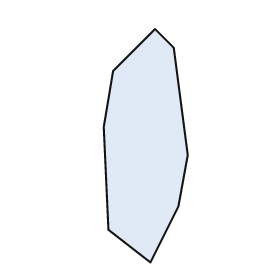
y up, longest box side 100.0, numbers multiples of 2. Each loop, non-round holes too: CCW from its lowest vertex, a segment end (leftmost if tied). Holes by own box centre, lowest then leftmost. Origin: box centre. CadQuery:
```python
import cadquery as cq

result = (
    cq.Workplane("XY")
    .moveTo(2.0, -50.0)
    .lineTo(14.0, -26.0)
    .lineTo(18.0, -4.0)
    .lineTo(12.0, 42.0)
    .lineTo(4.0, 50.0)
    .lineTo(-14.0, 32.0)
    .lineTo(-18.0, 8.0)
    .lineTo(-16.0, -36.0)
    .close()
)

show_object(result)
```